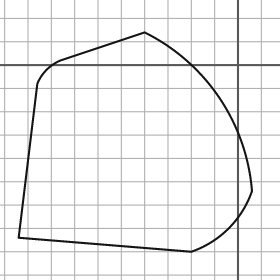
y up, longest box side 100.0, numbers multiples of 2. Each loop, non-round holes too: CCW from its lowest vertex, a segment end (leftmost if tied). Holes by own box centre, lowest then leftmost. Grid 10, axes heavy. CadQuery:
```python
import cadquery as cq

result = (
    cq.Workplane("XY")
    .moveTo(-20.0, -80.0)
    .threePointArc((-4.0, -70.0), (6.0, -54.0))
    .threePointArc((-8.0, -14.0), (-40.0, 14.0))
    .lineTo(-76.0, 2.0)
    .threePointArc((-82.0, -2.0), (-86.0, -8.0))
    .lineTo(-94.0, -74.0)
    .close()
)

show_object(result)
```